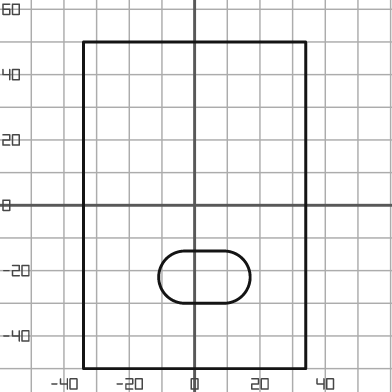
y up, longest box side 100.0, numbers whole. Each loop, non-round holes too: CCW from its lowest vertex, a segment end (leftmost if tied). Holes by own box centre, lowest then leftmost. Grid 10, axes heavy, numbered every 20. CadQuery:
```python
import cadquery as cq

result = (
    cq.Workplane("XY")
    .moveTo(-34.0, -50.0)
    .lineTo(34.0, -50.0)
    .lineTo(34.0, 50.0)
    .lineTo(-34.0, 50.0)
    .close()
    .moveTo(-3.0, -30.0)
    .lineTo(9.0, -30.0)
    .threePointArc((17.0, -22.0), (9.0, -14.0))
    .lineTo(-3.0, -14.0)
    .threePointArc((-11.0, -22.0), (-3.0, -30.0))
    .close()
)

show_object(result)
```